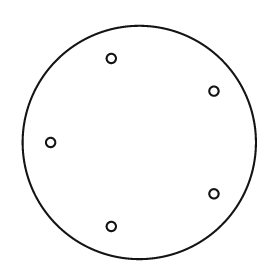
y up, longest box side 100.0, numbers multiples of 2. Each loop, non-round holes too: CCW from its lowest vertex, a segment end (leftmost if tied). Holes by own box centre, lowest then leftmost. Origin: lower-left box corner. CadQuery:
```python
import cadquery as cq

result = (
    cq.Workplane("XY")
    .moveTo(50.0, 50.0)
    .circle(50.0)
    .moveTo(38.0, 14.0)
    .circle(2.0)
    .moveTo(82.0, 28.0)
    .circle(2.0)
    .moveTo(12.0, 50.0)
    .circle(2.0)
    .moveTo(82.0, 72.0)
    .circle(2.0)
    .moveTo(38.0, 86.0)
    .circle(2.0)
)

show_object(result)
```